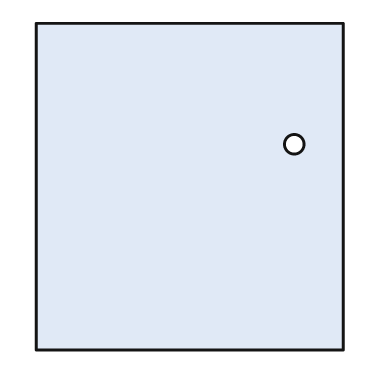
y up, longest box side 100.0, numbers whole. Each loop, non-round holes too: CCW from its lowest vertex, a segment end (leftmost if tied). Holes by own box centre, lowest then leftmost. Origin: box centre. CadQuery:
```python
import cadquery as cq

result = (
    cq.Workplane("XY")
    .moveTo(-47.0, -50.0)
    .lineTo(47.0, -50.0)
    .lineTo(47.0, 50.0)
    .lineTo(-47.0, 50.0)
    .close()
    .moveTo(32.0, 13.0)
    .circle(3.0)
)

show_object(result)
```